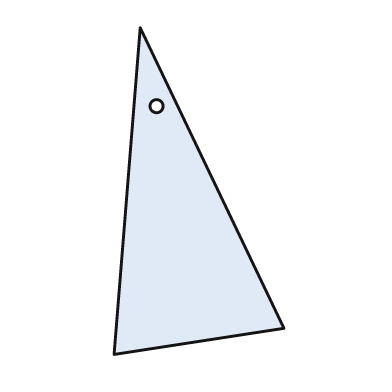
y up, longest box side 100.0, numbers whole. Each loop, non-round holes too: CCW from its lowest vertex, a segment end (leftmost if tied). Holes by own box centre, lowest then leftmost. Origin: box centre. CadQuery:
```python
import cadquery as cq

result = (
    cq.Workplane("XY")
    .moveTo(-26.0, -50.0)
    .lineTo(26.0, -42.0)
    .lineTo(-18.0, 50.0)
    .close()
    .moveTo(-13.0, 26.0)
    .circle(2.0)
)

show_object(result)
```